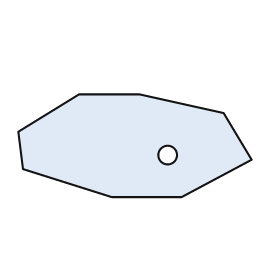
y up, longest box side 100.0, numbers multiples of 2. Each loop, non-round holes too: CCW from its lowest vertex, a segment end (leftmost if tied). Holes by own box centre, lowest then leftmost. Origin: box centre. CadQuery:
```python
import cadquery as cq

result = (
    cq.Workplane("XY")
    .moveTo(-10.0, -22.0)
    .lineTo(20.0, -22.0)
    .lineTo(50.0, -6.0)
    .lineTo(38.0, 14.0)
    .lineTo(2.0, 22.0)
    .lineTo(-24.0, 22.0)
    .lineTo(-50.0, 6.0)
    .lineTo(-48.0, -10.0)
    .close()
    .moveTo(14.0, -4.0)
    .circle(4.0)
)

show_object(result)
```